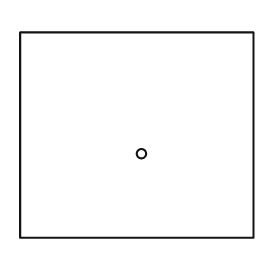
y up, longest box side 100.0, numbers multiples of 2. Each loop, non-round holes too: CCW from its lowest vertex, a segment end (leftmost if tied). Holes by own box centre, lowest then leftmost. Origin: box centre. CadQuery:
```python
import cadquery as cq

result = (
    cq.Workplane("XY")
    .moveTo(-50.0, -44.0)
    .lineTo(50.0, -44.0)
    .lineTo(50.0, 44.0)
    .lineTo(-50.0, 44.0)
    .close()
    .moveTo(2.0, -8.0)
    .circle(2.0)
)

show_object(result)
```